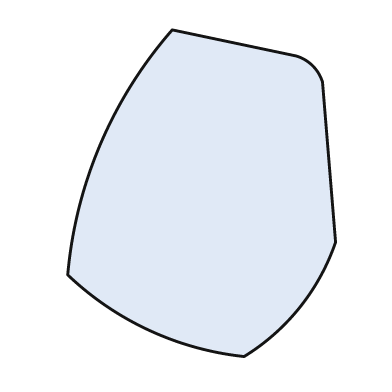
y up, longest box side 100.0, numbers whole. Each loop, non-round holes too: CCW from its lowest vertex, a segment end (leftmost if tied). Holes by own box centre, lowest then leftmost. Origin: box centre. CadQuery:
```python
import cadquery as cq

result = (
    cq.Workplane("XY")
    .moveTo(13.0, -50.0)
    .threePointArc((30.0, -35.0), (41.0, -15.0))
    .lineTo(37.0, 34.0)
    .threePointArc((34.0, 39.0), (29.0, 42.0))
    .lineTo(-9.0, 50.0)
    .threePointArc((-31.0, 15.0), (-41.0, -25.0))
    .threePointArc((-16.0, -42.0), (13.0, -50.0))
    .close()
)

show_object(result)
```